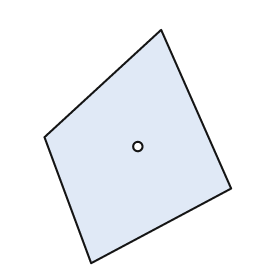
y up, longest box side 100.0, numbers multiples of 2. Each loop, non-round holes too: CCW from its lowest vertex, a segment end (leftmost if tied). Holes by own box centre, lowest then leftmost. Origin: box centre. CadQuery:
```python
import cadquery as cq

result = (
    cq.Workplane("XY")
    .moveTo(-20.0, -50.0)
    .lineTo(40.0, -18.0)
    .lineTo(10.0, 50.0)
    .lineTo(-40.0, 4.0)
    .close()
    .moveTo(0.0, 0.0)
    .circle(2.0)
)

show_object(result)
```